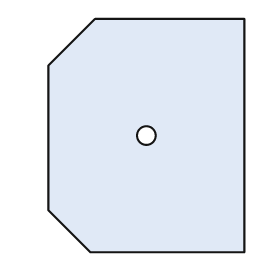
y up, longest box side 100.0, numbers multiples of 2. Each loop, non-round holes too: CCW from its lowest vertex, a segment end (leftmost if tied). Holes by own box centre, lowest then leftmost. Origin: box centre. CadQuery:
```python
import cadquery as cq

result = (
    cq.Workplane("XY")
    .moveTo(-24.0, -50.0)
    .lineTo(42.0, -50.0)
    .lineTo(42.0, 50.0)
    .lineTo(-22.0, 50.0)
    .lineTo(-42.0, 30.0)
    .lineTo(-42.0, -32.0)
    .close()
    .moveTo(0.0, 0.0)
    .circle(4.0)
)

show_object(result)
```